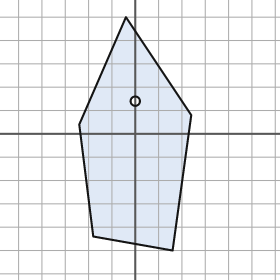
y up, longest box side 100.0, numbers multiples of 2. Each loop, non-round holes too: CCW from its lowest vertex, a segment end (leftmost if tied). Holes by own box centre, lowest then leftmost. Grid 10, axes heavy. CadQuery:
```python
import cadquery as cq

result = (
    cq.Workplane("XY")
    .moveTo(16.0, -50.0)
    .lineTo(24.0, 8.0)
    .lineTo(-4.0, 50.0)
    .lineTo(-24.0, 4.0)
    .lineTo(-18.0, -44.0)
    .close()
    .moveTo(0.0, 14.0)
    .circle(2.0)
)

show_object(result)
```